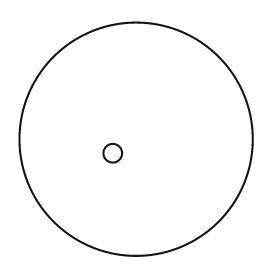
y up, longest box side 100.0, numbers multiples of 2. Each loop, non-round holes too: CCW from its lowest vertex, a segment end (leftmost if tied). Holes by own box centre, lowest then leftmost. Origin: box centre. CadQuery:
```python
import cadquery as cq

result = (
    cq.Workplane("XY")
    .moveTo(0.0, 0.0)
    .circle(50.0)
    .moveTo(-10.0, -6.0)
    .circle(4.0)
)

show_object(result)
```